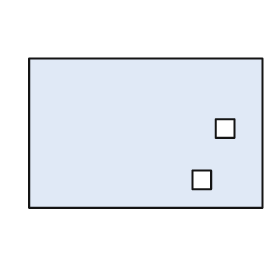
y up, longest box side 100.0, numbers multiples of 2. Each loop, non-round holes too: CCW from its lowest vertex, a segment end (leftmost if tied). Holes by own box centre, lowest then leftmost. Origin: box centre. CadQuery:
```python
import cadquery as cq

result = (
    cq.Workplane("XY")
    .moveTo(-50.0, -32.0)
    .lineTo(50.0, -32.0)
    .lineTo(50.0, 32.0)
    .lineTo(-50.0, 32.0)
    .close()
    .moveTo(20.0, -24.0)
    .lineTo(28.0, -24.0)
    .lineTo(28.0, -16.0)
    .lineTo(20.0, -16.0)
    .close()
    .moveTo(30.0, -2.0)
    .lineTo(38.0, -2.0)
    .lineTo(38.0, 6.0)
    .lineTo(30.0, 6.0)
    .close()
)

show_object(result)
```